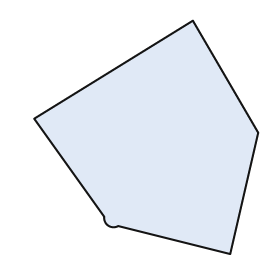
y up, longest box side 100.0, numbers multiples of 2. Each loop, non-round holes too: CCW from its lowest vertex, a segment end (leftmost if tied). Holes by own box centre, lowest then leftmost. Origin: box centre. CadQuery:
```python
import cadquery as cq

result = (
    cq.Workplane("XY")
    .moveTo(36.0, -50.0)
    .lineTo(48.0, 2.0)
    .lineTo(20.0, 50.0)
    .lineTo(-48.0, 8.0)
    .lineTo(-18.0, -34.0)
    .threePointArc((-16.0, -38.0), (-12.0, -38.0))
    .close()
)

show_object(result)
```